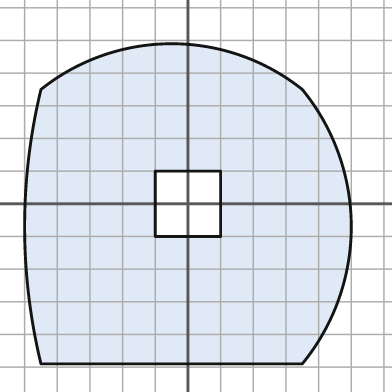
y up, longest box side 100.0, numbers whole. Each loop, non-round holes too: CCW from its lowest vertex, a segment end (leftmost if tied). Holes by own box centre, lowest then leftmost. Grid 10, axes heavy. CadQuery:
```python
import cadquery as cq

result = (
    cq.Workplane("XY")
    .moveTo(-45.0, -49.0)
    .lineTo(35.0, -49.0)
    .threePointArc((50.0, -7.0), (35.0, 35.0))
    .threePointArc((-5.0, 49.0), (-45.0, 35.0))
    .threePointArc((-50.0, -7.0), (-45.0, -49.0))
    .close()
    .moveTo(-10.0, -10.0)
    .lineTo(10.0, -10.0)
    .lineTo(10.0, 10.0)
    .lineTo(-10.0, 10.0)
    .close()
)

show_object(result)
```